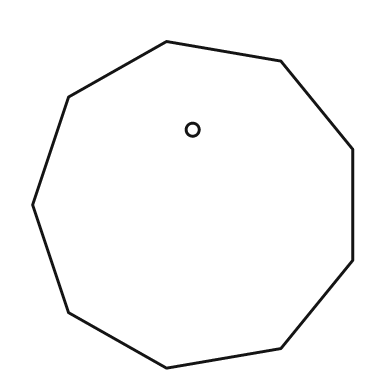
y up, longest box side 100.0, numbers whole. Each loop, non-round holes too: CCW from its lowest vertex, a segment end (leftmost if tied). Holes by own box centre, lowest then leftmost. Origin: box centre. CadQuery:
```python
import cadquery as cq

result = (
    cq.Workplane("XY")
    .moveTo(-8.0, -50.0)
    .lineTo(27.0, -44.0)
    .lineTo(49.0, -17.0)
    .lineTo(49.0, 17.0)
    .lineTo(27.0, 44.0)
    .lineTo(-8.0, 50.0)
    .lineTo(-38.0, 33.0)
    .lineTo(-49.0, 0.0)
    .lineTo(-38.0, -33.0)
    .close()
    .moveTo(0.0, 23.0)
    .circle(2.0)
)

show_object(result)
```